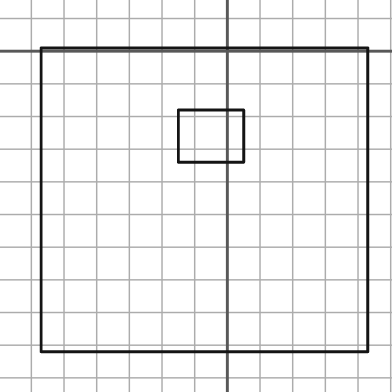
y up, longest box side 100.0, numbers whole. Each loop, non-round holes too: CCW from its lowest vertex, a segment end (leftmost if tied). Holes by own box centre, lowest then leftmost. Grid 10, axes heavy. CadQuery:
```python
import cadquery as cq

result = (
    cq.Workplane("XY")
    .moveTo(-57.0, -92.0)
    .lineTo(43.0, -92.0)
    .lineTo(43.0, 1.0)
    .lineTo(-57.0, 1.0)
    .close()
    .moveTo(-15.0, -34.0)
    .lineTo(5.0, -34.0)
    .lineTo(5.0, -18.0)
    .lineTo(-15.0, -18.0)
    .close()
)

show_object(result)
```